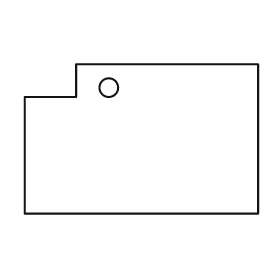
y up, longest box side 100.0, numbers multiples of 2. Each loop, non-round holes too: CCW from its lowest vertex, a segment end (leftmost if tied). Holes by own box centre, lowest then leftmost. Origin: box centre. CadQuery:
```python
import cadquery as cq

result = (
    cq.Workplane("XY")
    .moveTo(-50.0, -32.0)
    .lineTo(50.0, -32.0)
    .lineTo(50.0, 32.0)
    .lineTo(-28.0, 32.0)
    .lineTo(-28.0, 18.0)
    .lineTo(-50.0, 18.0)
    .close()
    .moveTo(-14.0, 22.0)
    .circle(4.0)
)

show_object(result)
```